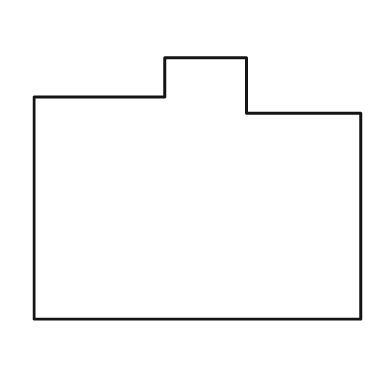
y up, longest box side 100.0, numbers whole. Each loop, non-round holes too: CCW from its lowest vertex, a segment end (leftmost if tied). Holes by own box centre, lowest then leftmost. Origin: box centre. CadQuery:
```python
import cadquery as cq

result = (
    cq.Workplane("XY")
    .moveTo(-50.0, -40.0)
    .lineTo(50.0, -40.0)
    .lineTo(50.0, 23.0)
    .lineTo(15.0, 23.0)
    .lineTo(15.0, 40.0)
    .lineTo(-10.0, 40.0)
    .lineTo(-10.0, 28.0)
    .lineTo(-50.0, 28.0)
    .close()
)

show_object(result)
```